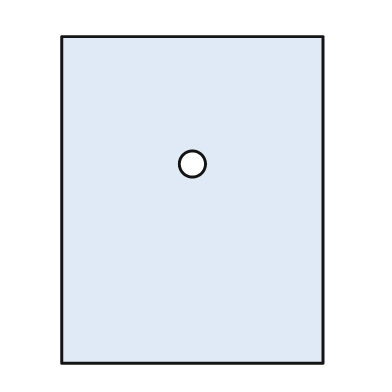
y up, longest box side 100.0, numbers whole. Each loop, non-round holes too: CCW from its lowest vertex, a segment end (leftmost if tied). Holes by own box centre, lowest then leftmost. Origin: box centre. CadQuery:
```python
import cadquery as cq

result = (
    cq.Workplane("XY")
    .moveTo(-40.0, -50.0)
    .lineTo(40.0, -50.0)
    .lineTo(40.0, 50.0)
    .lineTo(-40.0, 50.0)
    .close()
    .moveTo(0.0, 11.0)
    .circle(4.0)
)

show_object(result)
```